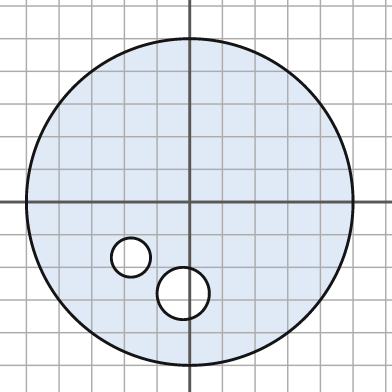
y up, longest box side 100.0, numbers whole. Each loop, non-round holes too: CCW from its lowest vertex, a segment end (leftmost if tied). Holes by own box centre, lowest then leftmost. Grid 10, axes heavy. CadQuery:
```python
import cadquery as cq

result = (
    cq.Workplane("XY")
    .moveTo(0.0, 0.0)
    .circle(50.0)
    .moveTo(-2.0, -28.0)
    .circle(8.0)
    .moveTo(-18.0, -17.0)
    .circle(6.0)
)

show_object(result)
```